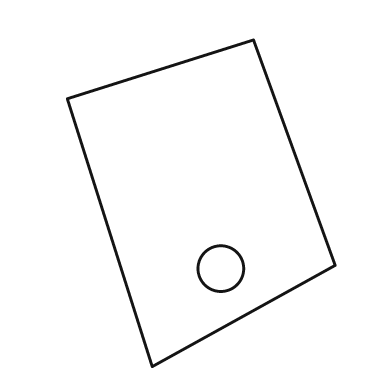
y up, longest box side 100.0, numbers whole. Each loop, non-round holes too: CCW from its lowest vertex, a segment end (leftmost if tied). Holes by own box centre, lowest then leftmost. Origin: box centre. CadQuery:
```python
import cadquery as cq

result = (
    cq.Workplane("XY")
    .moveTo(-15.0, -50.0)
    .lineTo(41.0, -19.0)
    .lineTo(16.0, 50.0)
    .lineTo(-41.0, 32.0)
    .close()
    .moveTo(6.0, -20.0)
    .circle(7.0)
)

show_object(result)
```